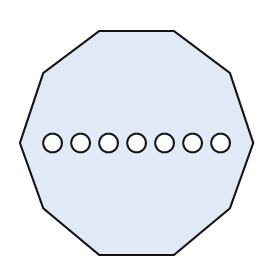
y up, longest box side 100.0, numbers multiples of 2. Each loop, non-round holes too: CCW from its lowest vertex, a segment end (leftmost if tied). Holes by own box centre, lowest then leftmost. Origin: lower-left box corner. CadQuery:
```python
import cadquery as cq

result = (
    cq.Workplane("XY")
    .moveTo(34.0, 0.0)
    .lineTo(66.0, 0.0)
    .lineTo(90.0, 20.0)
    .lineTo(100.0, 48.0)
    .lineTo(90.0, 78.0)
    .lineTo(66.0, 96.0)
    .lineTo(34.0, 96.0)
    .lineTo(10.0, 78.0)
    .lineTo(0.0, 48.0)
    .lineTo(10.0, 20.0)
    .close()
    .moveTo(14.0, 48.0)
    .circle(4.0)
    .moveTo(26.0, 48.0)
    .circle(4.0)
    .moveTo(38.0, 48.0)
    .circle(4.0)
    .moveTo(50.0, 48.0)
    .circle(4.0)
    .moveTo(62.0, 48.0)
    .circle(4.0)
    .moveTo(74.0, 48.0)
    .circle(4.0)
    .moveTo(86.0, 48.0)
    .circle(4.0)
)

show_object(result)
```